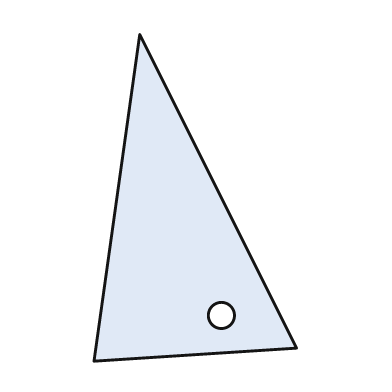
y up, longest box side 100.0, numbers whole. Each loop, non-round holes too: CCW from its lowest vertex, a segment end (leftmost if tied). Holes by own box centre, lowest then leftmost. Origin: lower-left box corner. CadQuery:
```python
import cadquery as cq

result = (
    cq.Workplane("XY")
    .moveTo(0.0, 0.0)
    .lineTo(62.0, 4.0)
    .lineTo(14.0, 100.0)
    .close()
    .moveTo(39.0, 14.0)
    .circle(4.0)
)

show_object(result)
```